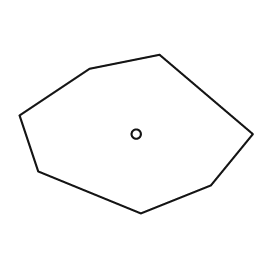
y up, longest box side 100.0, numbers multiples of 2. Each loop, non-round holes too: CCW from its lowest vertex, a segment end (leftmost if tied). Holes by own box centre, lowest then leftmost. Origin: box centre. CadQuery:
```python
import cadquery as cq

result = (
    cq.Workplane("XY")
    .moveTo(2.0, -34.0)
    .lineTo(32.0, -22.0)
    .lineTo(50.0, 0.0)
    .lineTo(10.0, 34.0)
    .lineTo(-20.0, 28.0)
    .lineTo(-50.0, 8.0)
    .lineTo(-42.0, -16.0)
    .close()
    .moveTo(0.0, 0.0)
    .circle(2.0)
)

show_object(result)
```